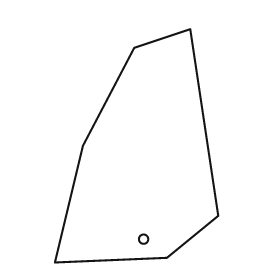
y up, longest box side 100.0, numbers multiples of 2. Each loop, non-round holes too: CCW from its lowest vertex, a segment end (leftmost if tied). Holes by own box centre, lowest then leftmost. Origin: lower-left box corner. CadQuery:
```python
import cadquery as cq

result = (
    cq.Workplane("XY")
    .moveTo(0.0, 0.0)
    .lineTo(48.0, 2.0)
    .lineTo(70.0, 20.0)
    .lineTo(58.0, 100.0)
    .lineTo(34.0, 92.0)
    .lineTo(12.0, 50.0)
    .close()
    .moveTo(38.0, 10.0)
    .circle(2.0)
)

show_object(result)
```